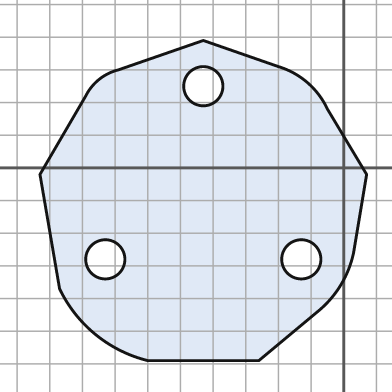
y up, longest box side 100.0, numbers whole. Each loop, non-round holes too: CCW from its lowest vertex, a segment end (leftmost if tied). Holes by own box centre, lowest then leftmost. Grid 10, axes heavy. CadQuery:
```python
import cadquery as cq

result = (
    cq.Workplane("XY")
    .moveTo(-60.0, -59.0)
    .lineTo(-26.0, -59.0)
    .lineTo(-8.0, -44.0)
    .threePointArc((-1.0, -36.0), (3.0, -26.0))
    .lineTo(7.0, -2.0)
    .lineTo(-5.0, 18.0)
    .threePointArc((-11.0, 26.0), (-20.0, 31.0))
    .lineTo(-43.0, 39.0)
    .lineTo(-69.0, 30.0)
    .threePointArc((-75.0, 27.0), (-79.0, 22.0))
    .lineTo(-93.0, -2.0)
    .lineTo(-87.0, -37.0)
    .threePointArc((-76.0, -51.0), (-60.0, -59.0))
    .close()
    .moveTo(-73.0, -28.0)
    .circle(6.0)
    .moveTo(-13.0, -28.0)
    .circle(6.0)
    .moveTo(-43.0, 25.0)
    .circle(6.0)
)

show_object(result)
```